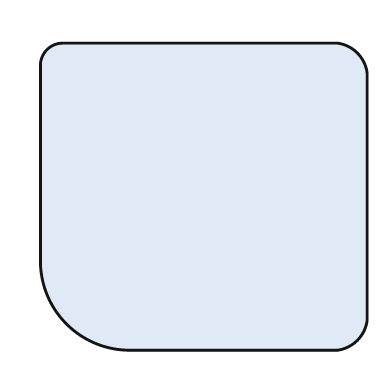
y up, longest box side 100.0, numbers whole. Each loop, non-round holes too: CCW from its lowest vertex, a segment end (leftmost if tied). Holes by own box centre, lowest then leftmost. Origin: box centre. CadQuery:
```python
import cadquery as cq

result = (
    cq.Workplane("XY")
    .moveTo(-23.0, -47.0)
    .lineTo(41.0, -47.0)
    .threePointArc((47.0, -44.0), (50.0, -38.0))
    .lineTo(50.0, 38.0)
    .threePointArc((47.0, 44.0), (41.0, 47.0))
    .lineTo(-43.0, 47.0)
    .threePointArc((-48.0, 45.0), (-50.0, 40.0))
    .lineTo(-50.0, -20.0)
    .threePointArc((-42.0, -39.0), (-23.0, -47.0))
    .close()
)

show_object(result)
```